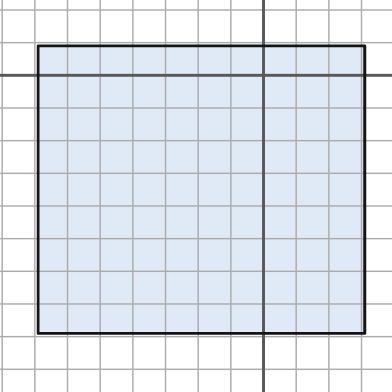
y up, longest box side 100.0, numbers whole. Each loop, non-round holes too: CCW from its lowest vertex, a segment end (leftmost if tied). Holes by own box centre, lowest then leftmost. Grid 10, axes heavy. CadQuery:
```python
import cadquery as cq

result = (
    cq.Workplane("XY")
    .moveTo(-69.0, -79.0)
    .lineTo(31.0, -79.0)
    .lineTo(31.0, 9.0)
    .lineTo(-69.0, 9.0)
    .close()
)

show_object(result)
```